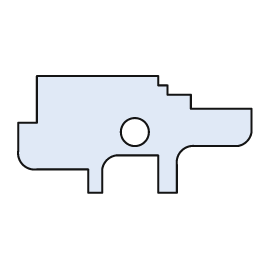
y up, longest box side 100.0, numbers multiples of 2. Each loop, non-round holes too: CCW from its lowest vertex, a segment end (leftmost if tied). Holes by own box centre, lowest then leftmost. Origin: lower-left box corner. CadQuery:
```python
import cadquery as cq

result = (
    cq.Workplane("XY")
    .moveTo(30.0, 0.0)
    .lineTo(36.0, 0.0)
    .lineTo(36.0, 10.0)
    .threePointArc((38.0, 14.0), (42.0, 16.0))
    .lineTo(60.0, 16.0)
    .lineTo(60.0, 0.0)
    .lineTo(68.0, 0.0)
    .lineTo(68.0, 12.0)
    .threePointArc((70.0, 18.0), (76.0, 20.0))
    .lineTo(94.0, 20.0)
    .threePointArc((98.0, 22.0), (100.0, 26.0))
    .lineTo(100.0, 36.0)
    .lineTo(74.0, 36.0)
    .lineTo(74.0, 42.0)
    .lineTo(64.0, 42.0)
    .lineTo(64.0, 46.0)
    .lineTo(60.0, 46.0)
    .lineTo(60.0, 50.0)
    .lineTo(8.0, 50.0)
    .lineTo(8.0, 30.0)
    .lineTo(0.0, 30.0)
    .lineTo(0.0, 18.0)
    .threePointArc((2.0, 12.0), (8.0, 10.0))
    .lineTo(30.0, 10.0)
    .close()
    .moveTo(50.0, 26.0)
    .circle(6.0)
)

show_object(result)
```